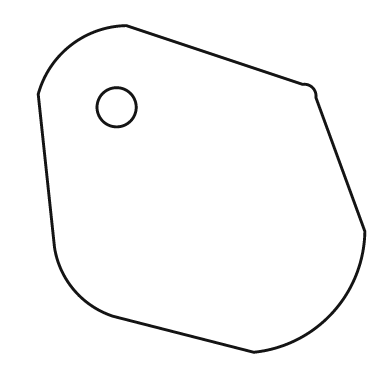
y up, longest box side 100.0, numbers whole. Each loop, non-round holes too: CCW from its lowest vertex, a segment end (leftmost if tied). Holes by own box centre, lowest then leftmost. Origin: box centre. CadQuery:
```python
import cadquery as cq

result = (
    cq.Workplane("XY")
    .moveTo(16.0, -50.0)
    .threePointArc((40.0, -38.0), (50.0, -13.0))
    .lineTo(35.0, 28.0)
    .threePointArc((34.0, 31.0), (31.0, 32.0))
    .lineTo(-23.0, 50.0)
    .threePointArc((-40.0, 44.0), (-50.0, 29.0))
    .lineTo(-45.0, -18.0)
    .threePointArc((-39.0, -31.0), (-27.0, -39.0))
    .close()
    .moveTo(-26.0, 25.0)
    .circle(6.0)
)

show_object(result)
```